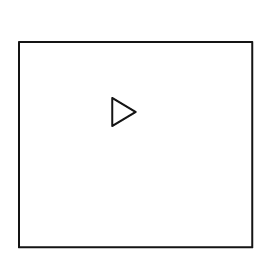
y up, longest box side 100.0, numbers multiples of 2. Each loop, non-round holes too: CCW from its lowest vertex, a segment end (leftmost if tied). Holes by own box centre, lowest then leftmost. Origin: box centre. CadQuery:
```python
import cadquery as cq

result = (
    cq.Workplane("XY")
    .moveTo(-50.0, -44.0)
    .lineTo(50.0, -44.0)
    .lineTo(50.0, 44.0)
    .lineTo(-50.0, 44.0)
    .close()
    .moveTo(-10.0, 8.0)
    .lineTo(0.0, 14.0)
    .lineTo(-10.0, 20.0)
    .close()
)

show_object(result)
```